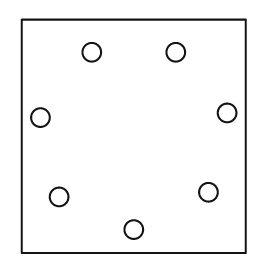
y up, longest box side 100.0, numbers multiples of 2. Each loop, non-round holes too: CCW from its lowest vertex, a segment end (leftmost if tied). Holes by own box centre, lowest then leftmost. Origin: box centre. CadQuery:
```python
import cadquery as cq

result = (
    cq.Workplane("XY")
    .moveTo(-48.0, -50.0)
    .lineTo(48.0, -50.0)
    .lineTo(48.0, 50.0)
    .lineTo(-48.0, 50.0)
    .close()
    .moveTo(0.0, -40.0)
    .circle(4.0)
    .moveTo(-32.0, -26.0)
    .circle(4.0)
    .moveTo(32.0, -24.0)
    .circle(4.0)
    .moveTo(-40.0, 8.0)
    .circle(4.0)
    .moveTo(40.0, 10.0)
    .circle(4.0)
    .moveTo(-18.0, 36.0)
    .circle(4.0)
    .moveTo(18.0, 36.0)
    .circle(4.0)
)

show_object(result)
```